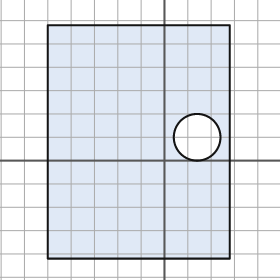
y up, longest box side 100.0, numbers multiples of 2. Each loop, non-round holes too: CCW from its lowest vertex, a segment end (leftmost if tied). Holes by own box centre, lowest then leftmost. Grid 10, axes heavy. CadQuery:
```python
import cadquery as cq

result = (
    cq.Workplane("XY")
    .moveTo(-50.0, -42.0)
    .lineTo(28.0, -42.0)
    .lineTo(28.0, 58.0)
    .lineTo(-50.0, 58.0)
    .close()
    .moveTo(14.0, 10.0)
    .circle(10.0)
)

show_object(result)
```